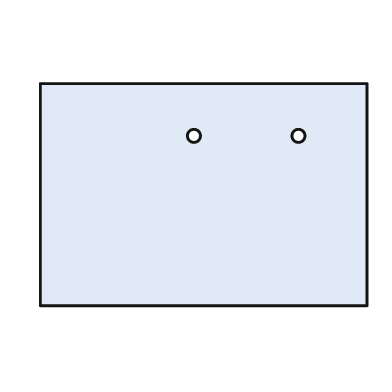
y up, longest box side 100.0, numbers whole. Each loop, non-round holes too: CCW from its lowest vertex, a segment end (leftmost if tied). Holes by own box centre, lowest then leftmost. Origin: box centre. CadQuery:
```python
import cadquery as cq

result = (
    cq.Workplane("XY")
    .moveTo(-50.0, -34.0)
    .lineTo(50.0, -34.0)
    .lineTo(50.0, 34.0)
    .lineTo(-50.0, 34.0)
    .close()
    .moveTo(-3.0, 18.0)
    .circle(2.0)
    .moveTo(29.0, 18.0)
    .circle(2.0)
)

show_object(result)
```